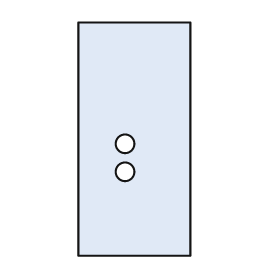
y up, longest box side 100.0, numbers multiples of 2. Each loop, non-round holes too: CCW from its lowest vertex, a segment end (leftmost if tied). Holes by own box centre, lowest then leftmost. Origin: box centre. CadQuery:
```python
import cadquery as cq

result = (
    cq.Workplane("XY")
    .moveTo(-24.0, -50.0)
    .lineTo(24.0, -50.0)
    .lineTo(24.0, 50.0)
    .lineTo(-24.0, 50.0)
    .close()
    .moveTo(-4.0, -14.0)
    .circle(4.0)
    .moveTo(-4.0, -2.0)
    .circle(4.0)
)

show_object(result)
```